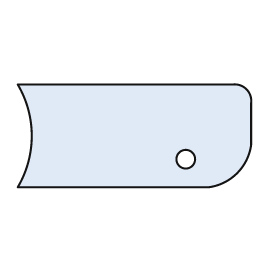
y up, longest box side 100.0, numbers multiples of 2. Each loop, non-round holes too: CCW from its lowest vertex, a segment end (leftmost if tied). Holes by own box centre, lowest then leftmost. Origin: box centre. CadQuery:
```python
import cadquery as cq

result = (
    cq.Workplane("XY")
    .moveTo(-50.0, -22.0)
    .lineTo(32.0, -22.0)
    .threePointArc((44.0, -16.0), (50.0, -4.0))
    .lineTo(50.0, 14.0)
    .threePointArc((48.0, 20.0), (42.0, 22.0))
    .lineTo(-50.0, 22.0)
    .threePointArc((-44.0, 0.0), (-50.0, -22.0))
    .close()
    .moveTo(22.0, -10.0)
    .circle(4.0)
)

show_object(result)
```